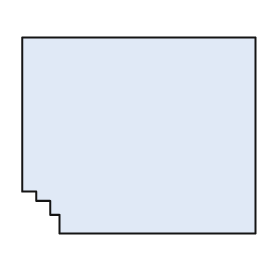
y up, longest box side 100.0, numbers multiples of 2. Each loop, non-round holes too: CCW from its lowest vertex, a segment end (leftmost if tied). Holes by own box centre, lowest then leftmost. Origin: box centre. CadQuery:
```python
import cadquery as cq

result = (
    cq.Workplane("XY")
    .moveTo(-34.0, -42.0)
    .lineTo(50.0, -42.0)
    .lineTo(50.0, 42.0)
    .lineTo(-50.0, 42.0)
    .lineTo(-50.0, -24.0)
    .lineTo(-44.0, -24.0)
    .lineTo(-44.0, -28.0)
    .lineTo(-38.0, -28.0)
    .lineTo(-38.0, -34.0)
    .lineTo(-34.0, -34.0)
    .close()
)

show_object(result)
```